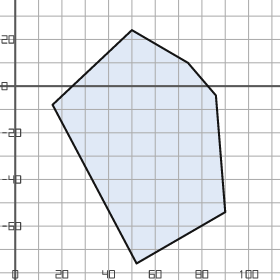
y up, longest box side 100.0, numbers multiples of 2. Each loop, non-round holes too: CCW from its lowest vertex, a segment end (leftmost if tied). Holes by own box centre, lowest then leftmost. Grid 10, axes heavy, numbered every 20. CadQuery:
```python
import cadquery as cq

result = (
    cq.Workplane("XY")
    .moveTo(52.0, -76.0)
    .lineTo(90.0, -54.0)
    .lineTo(86.0, -4.0)
    .lineTo(74.0, 10.0)
    .lineTo(50.0, 24.0)
    .lineTo(16.0, -8.0)
    .close()
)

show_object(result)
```